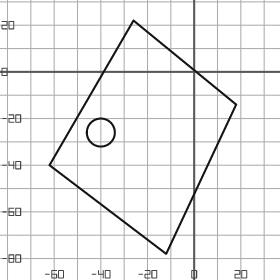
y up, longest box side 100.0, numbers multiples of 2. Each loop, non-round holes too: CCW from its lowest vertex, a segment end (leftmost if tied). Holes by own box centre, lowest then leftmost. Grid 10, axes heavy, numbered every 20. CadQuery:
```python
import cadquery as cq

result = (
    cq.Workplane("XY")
    .moveTo(-12.0, -78.0)
    .lineTo(18.0, -14.0)
    .lineTo(-26.0, 22.0)
    .lineTo(-62.0, -40.0)
    .close()
    .moveTo(-40.0, -26.0)
    .circle(6.0)
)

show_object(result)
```